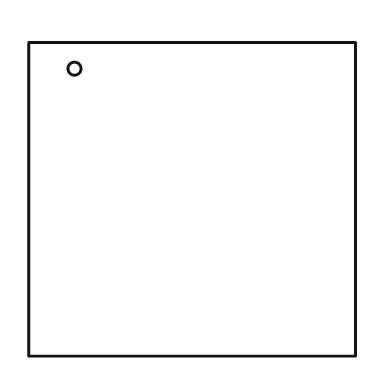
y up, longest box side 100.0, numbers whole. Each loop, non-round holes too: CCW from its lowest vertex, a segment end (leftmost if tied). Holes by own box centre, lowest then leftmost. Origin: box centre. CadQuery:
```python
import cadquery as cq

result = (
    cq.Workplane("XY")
    .moveTo(-50.0, -48.0)
    .lineTo(50.0, -48.0)
    .lineTo(50.0, 48.0)
    .lineTo(-50.0, 48.0)
    .close()
    .moveTo(-36.0, 40.0)
    .circle(2.0)
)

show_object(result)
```